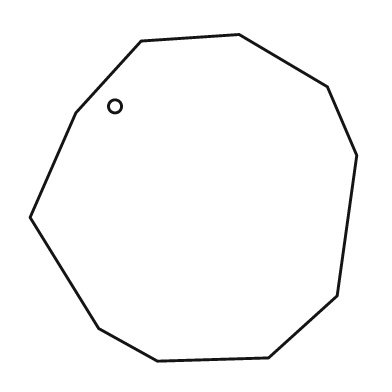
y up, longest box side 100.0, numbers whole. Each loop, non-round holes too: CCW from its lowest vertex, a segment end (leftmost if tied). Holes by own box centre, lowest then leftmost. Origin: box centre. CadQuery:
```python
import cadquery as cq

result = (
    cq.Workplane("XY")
    .moveTo(-11.0, -50.0)
    .lineTo(23.0, -49.0)
    .lineTo(44.0, -30.0)
    .lineTo(50.0, 13.0)
    .lineTo(41.0, 34.0)
    .lineTo(14.0, 50.0)
    .lineTo(-16.0, 48.0)
    .lineTo(-36.0, 26.0)
    .lineTo(-50.0, -6.0)
    .lineTo(-29.0, -40.0)
    .close()
    .moveTo(-24.0, 28.0)
    .circle(2.0)
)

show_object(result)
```